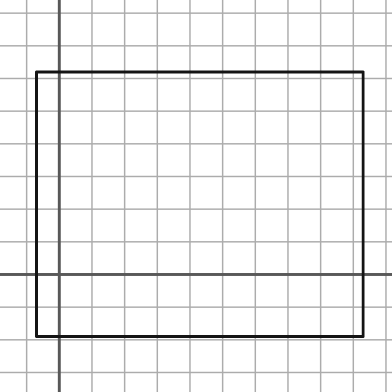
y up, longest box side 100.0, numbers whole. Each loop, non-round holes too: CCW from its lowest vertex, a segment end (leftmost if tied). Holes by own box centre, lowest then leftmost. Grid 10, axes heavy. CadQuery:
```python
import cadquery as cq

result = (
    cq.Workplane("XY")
    .moveTo(-7.0, -19.0)
    .lineTo(93.0, -19.0)
    .lineTo(93.0, 62.0)
    .lineTo(-7.0, 62.0)
    .close()
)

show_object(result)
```